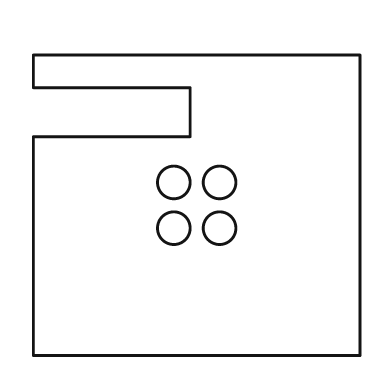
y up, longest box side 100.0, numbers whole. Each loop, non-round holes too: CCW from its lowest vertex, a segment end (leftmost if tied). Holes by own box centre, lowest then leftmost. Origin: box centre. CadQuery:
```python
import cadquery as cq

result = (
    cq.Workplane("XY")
    .moveTo(-50.0, -46.0)
    .lineTo(50.0, -46.0)
    .lineTo(50.0, 46.0)
    .lineTo(-50.0, 46.0)
    .lineTo(-50.0, 36.0)
    .lineTo(-2.0, 36.0)
    .lineTo(-2.0, 21.0)
    .lineTo(-50.0, 21.0)
    .close()
    .moveTo(-7.0, -7.0)
    .circle(5.0)
    .moveTo(7.0, -7.0)
    .circle(5.0)
    .moveTo(-7.0, 7.0)
    .circle(5.0)
    .moveTo(7.0, 7.0)
    .circle(5.0)
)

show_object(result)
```